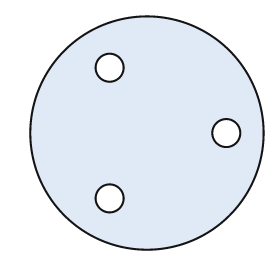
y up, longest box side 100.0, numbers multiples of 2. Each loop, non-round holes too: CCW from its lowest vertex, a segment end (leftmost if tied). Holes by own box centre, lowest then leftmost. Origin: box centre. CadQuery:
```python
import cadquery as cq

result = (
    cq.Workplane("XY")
    .moveTo(0.0, 0.0)
    .circle(50.0)
    .moveTo(-16.0, -28.0)
    .circle(6.0)
    .moveTo(34.0, 0.0)
    .circle(6.0)
    .moveTo(-16.0, 28.0)
    .circle(6.0)
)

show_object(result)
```